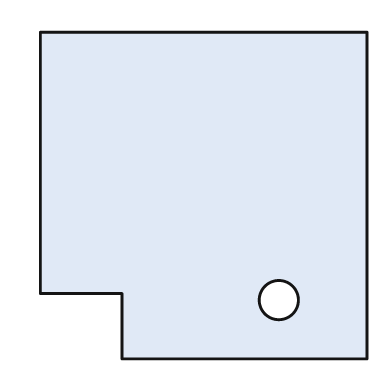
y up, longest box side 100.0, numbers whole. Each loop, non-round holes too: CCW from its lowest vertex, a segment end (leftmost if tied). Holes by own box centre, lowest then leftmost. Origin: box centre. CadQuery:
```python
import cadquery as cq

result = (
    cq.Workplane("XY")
    .moveTo(-25.0, -50.0)
    .lineTo(50.0, -50.0)
    .lineTo(50.0, 50.0)
    .lineTo(-50.0, 50.0)
    .lineTo(-50.0, -30.0)
    .lineTo(-25.0, -30.0)
    .close()
    .moveTo(23.0, -32.0)
    .circle(6.0)
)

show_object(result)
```